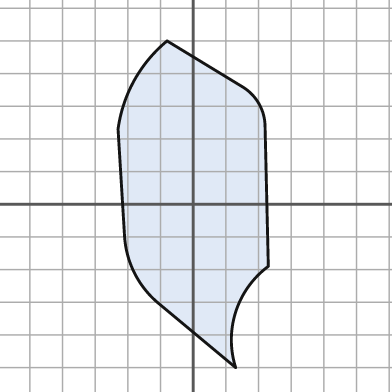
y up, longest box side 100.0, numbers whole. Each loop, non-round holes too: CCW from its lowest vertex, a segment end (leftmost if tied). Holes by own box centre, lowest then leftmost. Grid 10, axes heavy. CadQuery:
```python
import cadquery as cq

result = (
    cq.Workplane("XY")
    .moveTo(13.0, -50.0)
    .threePointArc((13.0, -33.0), (23.0, -19.0))
    .lineTo(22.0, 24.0)
    .threePointArc((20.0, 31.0), (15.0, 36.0))
    .lineTo(-8.0, 50.0)
    .threePointArc((-18.0, 38.0), (-23.0, 23.0))
    .lineTo(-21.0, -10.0)
    .threePointArc((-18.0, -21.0), (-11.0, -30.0))
    .close()
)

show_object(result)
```